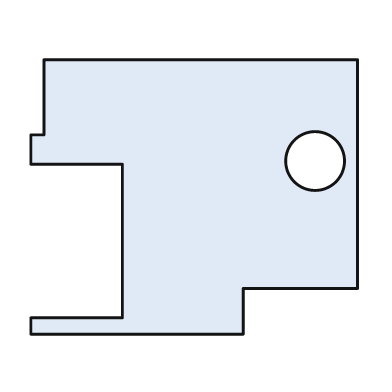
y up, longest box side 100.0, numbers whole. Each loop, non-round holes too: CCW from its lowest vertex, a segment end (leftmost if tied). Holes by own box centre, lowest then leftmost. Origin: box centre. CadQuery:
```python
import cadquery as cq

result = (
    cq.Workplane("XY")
    .moveTo(-50.0, -42.0)
    .lineTo(15.0, -42.0)
    .lineTo(15.0, -28.0)
    .lineTo(50.0, -28.0)
    .lineTo(50.0, 42.0)
    .lineTo(-46.0, 42.0)
    .lineTo(-46.0, 19.0)
    .lineTo(-50.0, 19.0)
    .lineTo(-50.0, 10.0)
    .lineTo(-22.0, 10.0)
    .lineTo(-22.0, -37.0)
    .lineTo(-50.0, -37.0)
    .close()
    .moveTo(37.0, 11.0)
    .circle(9.0)
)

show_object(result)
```